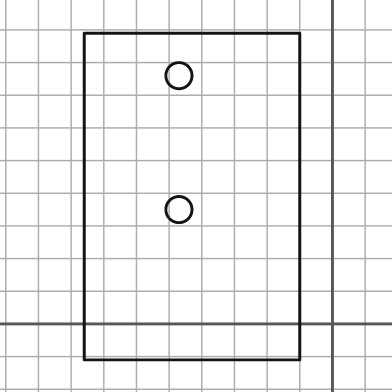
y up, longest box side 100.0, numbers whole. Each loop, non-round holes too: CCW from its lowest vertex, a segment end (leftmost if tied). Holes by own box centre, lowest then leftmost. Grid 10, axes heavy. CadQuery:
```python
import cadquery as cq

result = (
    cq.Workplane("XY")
    .moveTo(-76.0, -11.0)
    .lineTo(-10.0, -11.0)
    .lineTo(-10.0, 89.0)
    .lineTo(-76.0, 89.0)
    .close()
    .moveTo(-47.0, 35.0)
    .circle(4.0)
    .moveTo(-47.0, 76.0)
    .circle(4.0)
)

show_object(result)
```